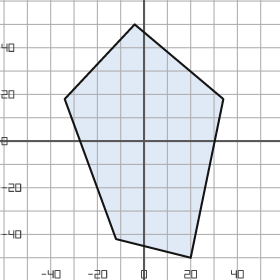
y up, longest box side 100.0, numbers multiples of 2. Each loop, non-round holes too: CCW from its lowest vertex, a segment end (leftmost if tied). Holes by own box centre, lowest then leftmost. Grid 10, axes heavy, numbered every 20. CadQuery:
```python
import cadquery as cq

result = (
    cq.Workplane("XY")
    .moveTo(20.0, -50.0)
    .lineTo(34.0, 18.0)
    .lineTo(-4.0, 50.0)
    .lineTo(-34.0, 18.0)
    .lineTo(-12.0, -42.0)
    .close()
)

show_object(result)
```